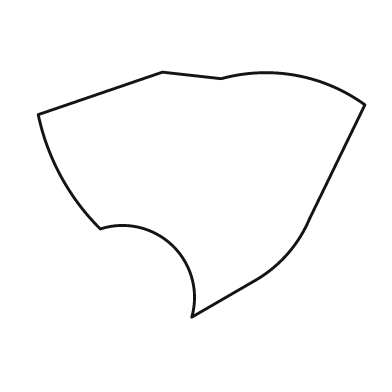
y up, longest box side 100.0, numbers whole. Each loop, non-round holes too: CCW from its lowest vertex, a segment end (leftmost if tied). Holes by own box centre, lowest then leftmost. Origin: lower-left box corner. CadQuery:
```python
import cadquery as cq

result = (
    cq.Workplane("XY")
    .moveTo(47.0, 0.0)
    .lineTo(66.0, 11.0)
    .threePointArc((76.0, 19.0), (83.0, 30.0))
    .lineTo(100.0, 65.0)
    .threePointArc((79.0, 74.0), (56.0, 73.0))
    .lineTo(38.0, 75.0)
    .lineTo(0.0, 62.0)
    .threePointArc((7.0, 43.0), (19.0, 27.0))
    .threePointArc((41.0, 22.0), (47.0, 0.0))
    .close()
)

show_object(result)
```